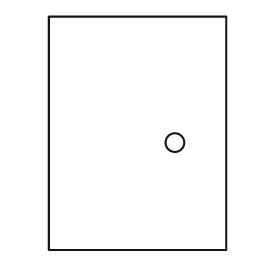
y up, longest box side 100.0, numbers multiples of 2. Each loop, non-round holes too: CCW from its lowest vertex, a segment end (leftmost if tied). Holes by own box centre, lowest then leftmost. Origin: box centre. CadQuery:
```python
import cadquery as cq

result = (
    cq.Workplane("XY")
    .moveTo(-38.0, -50.0)
    .lineTo(38.0, -50.0)
    .lineTo(38.0, 50.0)
    .lineTo(-38.0, 50.0)
    .close()
    .moveTo(16.0, -4.0)
    .circle(4.0)
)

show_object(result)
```